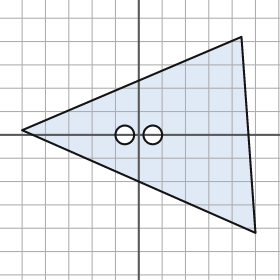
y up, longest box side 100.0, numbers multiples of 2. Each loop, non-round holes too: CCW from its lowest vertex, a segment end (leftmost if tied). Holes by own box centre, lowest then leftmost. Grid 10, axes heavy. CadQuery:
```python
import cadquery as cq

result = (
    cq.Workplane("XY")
    .moveTo(50.0, -42.0)
    .lineTo(44.0, 42.0)
    .lineTo(-50.0, 2.0)
    .close()
    .moveTo(-6.0, 0.0)
    .circle(4.0)
    .moveTo(6.0, 0.0)
    .circle(4.0)
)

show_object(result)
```